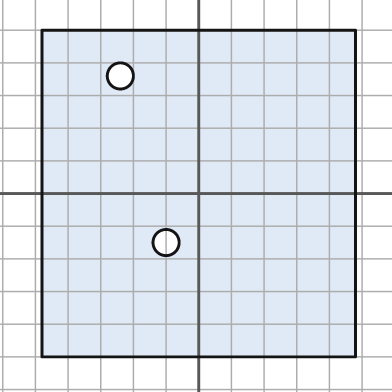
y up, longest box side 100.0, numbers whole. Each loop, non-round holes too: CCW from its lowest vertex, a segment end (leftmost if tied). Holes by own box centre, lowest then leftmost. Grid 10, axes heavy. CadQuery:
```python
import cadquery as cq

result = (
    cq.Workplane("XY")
    .moveTo(-48.0, -50.0)
    .lineTo(48.0, -50.0)
    .lineTo(48.0, 50.0)
    .lineTo(-48.0, 50.0)
    .close()
    .moveTo(-10.0, -15.0)
    .circle(4.0)
    .moveTo(-24.0, 36.0)
    .circle(4.0)
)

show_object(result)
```